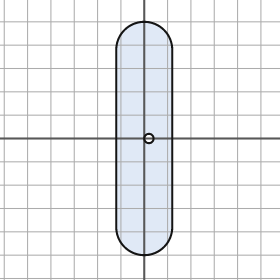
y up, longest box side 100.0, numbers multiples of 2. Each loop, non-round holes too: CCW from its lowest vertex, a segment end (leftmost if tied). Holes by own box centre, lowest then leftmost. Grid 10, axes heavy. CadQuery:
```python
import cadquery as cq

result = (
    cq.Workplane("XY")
    .moveTo(-12.0, -38.0)
    .threePointArc((0.0, -50.0), (12.0, -38.0))
    .lineTo(12.0, 38.0)
    .threePointArc((0.0, 50.0), (-12.0, 38.0))
    .close()
    .moveTo(2.0, 0.0)
    .circle(2.0)
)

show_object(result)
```